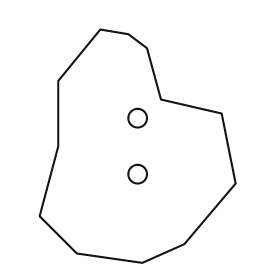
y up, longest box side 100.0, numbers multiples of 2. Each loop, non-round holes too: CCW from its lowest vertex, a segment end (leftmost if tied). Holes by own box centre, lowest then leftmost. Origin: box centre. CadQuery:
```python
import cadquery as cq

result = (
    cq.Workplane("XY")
    .moveTo(2.0, -50.0)
    .lineTo(20.0, -42.0)
    .lineTo(42.0, -16.0)
    .lineTo(36.0, 14.0)
    .lineTo(10.0, 20.0)
    .lineTo(4.0, 42.0)
    .lineTo(-4.0, 48.0)
    .lineTo(-16.0, 50.0)
    .lineTo(-34.0, 28.0)
    .lineTo(-34.0, 0.0)
    .lineTo(-42.0, -30.0)
    .lineTo(-26.0, -46.0)
    .close()
    .moveTo(0.0, -12.0)
    .circle(4.0)
    .moveTo(0.0, 12.0)
    .circle(4.0)
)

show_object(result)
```